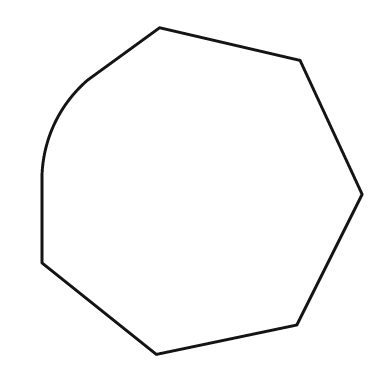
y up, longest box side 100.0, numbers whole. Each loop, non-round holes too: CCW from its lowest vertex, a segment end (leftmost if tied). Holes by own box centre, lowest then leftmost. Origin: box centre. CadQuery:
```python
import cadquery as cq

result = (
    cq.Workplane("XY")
    .moveTo(-14.0, -50.0)
    .lineTo(29.0, -41.0)
    .lineTo(49.0, -1.0)
    .lineTo(30.0, 40.0)
    .lineTo(-13.0, 50.0)
    .lineTo(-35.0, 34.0)
    .threePointArc((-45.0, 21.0), (-49.0, 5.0))
    .lineTo(-49.0, -22.0)
    .close()
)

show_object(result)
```